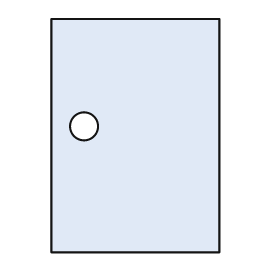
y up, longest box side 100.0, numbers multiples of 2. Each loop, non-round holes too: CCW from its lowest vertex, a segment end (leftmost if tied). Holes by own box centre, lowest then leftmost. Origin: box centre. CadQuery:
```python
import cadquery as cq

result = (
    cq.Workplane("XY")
    .moveTo(-36.0, -50.0)
    .lineTo(36.0, -50.0)
    .lineTo(36.0, 50.0)
    .lineTo(-36.0, 50.0)
    .close()
    .moveTo(-22.0, 4.0)
    .circle(6.0)
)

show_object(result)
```